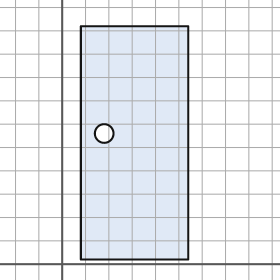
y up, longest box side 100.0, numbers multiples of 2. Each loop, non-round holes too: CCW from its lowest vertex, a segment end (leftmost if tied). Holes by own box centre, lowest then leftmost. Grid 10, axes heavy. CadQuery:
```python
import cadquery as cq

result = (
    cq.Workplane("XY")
    .moveTo(8.0, 2.0)
    .lineTo(54.0, 2.0)
    .lineTo(54.0, 102.0)
    .lineTo(8.0, 102.0)
    .close()
    .moveTo(18.0, 56.0)
    .circle(4.0)
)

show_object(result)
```